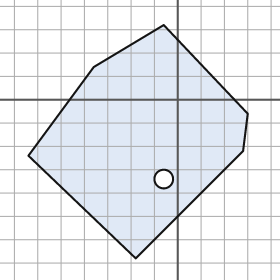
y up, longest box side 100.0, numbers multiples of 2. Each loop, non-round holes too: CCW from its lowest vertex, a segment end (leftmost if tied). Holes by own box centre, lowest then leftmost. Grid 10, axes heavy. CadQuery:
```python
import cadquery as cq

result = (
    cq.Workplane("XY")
    .moveTo(-18.0, -68.0)
    .lineTo(28.0, -22.0)
    .lineTo(30.0, -6.0)
    .lineTo(-6.0, 32.0)
    .lineTo(-36.0, 14.0)
    .lineTo(-64.0, -24.0)
    .close()
    .moveTo(-6.0, -34.0)
    .circle(4.0)
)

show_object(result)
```